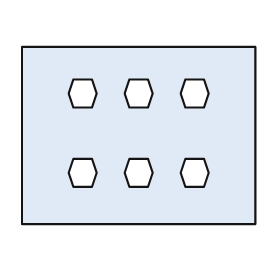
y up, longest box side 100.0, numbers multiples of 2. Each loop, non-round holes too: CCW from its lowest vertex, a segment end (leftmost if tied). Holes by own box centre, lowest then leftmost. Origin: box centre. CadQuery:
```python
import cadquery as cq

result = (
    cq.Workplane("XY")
    .moveTo(-50.0, -38.0)
    .lineTo(50.0, -38.0)
    .lineTo(50.0, 38.0)
    .lineTo(-50.0, 38.0)
    .close()
    .moveTo(-28.0, -22.0)
    .lineTo(-20.0, -22.0)
    .lineTo(-18.0, -16.0)
    .lineTo(-20.0, -10.0)
    .lineTo(-28.0, -10.0)
    .lineTo(-30.0, -16.0)
    .close()
    .moveTo(-4.0, -22.0)
    .lineTo(4.0, -22.0)
    .lineTo(6.0, -16.0)
    .lineTo(4.0, -10.0)
    .lineTo(-4.0, -10.0)
    .lineTo(-6.0, -16.0)
    .close()
    .moveTo(20.0, -22.0)
    .lineTo(28.0, -22.0)
    .lineTo(30.0, -16.0)
    .lineTo(28.0, -10.0)
    .lineTo(20.0, -10.0)
    .lineTo(18.0, -16.0)
    .close()
    .moveTo(-28.0, 12.0)
    .lineTo(-20.0, 12.0)
    .lineTo(-18.0, 18.0)
    .lineTo(-20.0, 24.0)
    .lineTo(-28.0, 24.0)
    .lineTo(-30.0, 18.0)
    .close()
    .moveTo(-4.0, 12.0)
    .lineTo(4.0, 12.0)
    .lineTo(6.0, 18.0)
    .lineTo(4.0, 24.0)
    .lineTo(-4.0, 24.0)
    .lineTo(-6.0, 18.0)
    .close()
    .moveTo(20.0, 12.0)
    .lineTo(28.0, 12.0)
    .lineTo(30.0, 18.0)
    .lineTo(28.0, 24.0)
    .lineTo(20.0, 24.0)
    .lineTo(18.0, 18.0)
    .close()
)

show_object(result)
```